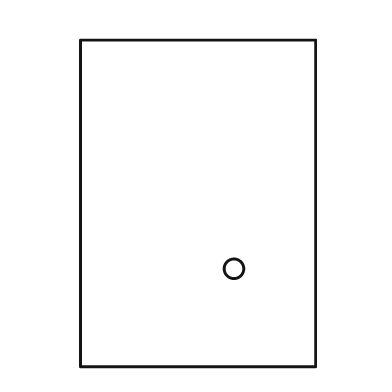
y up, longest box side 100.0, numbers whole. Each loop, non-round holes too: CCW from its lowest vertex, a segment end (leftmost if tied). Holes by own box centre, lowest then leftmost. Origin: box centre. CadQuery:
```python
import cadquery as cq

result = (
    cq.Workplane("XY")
    .moveTo(-36.0, -50.0)
    .lineTo(36.0, -50.0)
    .lineTo(36.0, 50.0)
    .lineTo(-36.0, 50.0)
    .close()
    .moveTo(11.0, -20.0)
    .circle(3.0)
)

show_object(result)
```